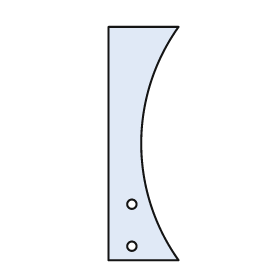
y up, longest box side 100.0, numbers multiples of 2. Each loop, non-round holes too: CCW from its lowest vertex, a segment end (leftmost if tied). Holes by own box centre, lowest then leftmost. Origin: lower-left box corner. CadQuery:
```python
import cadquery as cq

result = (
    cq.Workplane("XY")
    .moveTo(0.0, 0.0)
    .lineTo(30.0, 0.0)
    .threePointArc((14.0, 50.0), (30.0, 100.0))
    .lineTo(0.0, 100.0)
    .close()
    .moveTo(10.0, 6.0)
    .circle(2.0)
    .moveTo(10.0, 24.0)
    .circle(2.0)
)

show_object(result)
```